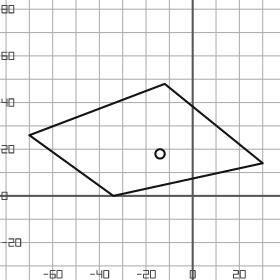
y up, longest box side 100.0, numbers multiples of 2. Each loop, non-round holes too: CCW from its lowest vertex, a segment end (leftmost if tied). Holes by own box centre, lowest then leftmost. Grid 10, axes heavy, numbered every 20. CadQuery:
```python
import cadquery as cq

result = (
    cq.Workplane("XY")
    .moveTo(-34.0, 0.0)
    .lineTo(30.0, 14.0)
    .lineTo(-12.0, 48.0)
    .lineTo(-70.0, 26.0)
    .close()
    .moveTo(-14.0, 18.0)
    .circle(2.0)
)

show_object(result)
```